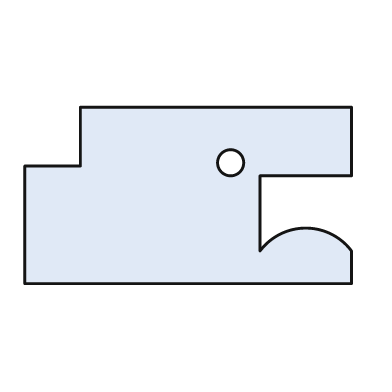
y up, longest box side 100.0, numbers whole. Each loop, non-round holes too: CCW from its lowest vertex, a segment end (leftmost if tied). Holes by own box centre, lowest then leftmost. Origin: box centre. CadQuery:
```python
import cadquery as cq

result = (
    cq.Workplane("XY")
    .moveTo(-50.0, -27.0)
    .lineTo(50.0, -27.0)
    .lineTo(50.0, -17.0)
    .threePointArc((36.0, -10.0), (22.0, -17.0))
    .lineTo(22.0, 6.0)
    .lineTo(50.0, 6.0)
    .lineTo(50.0, 27.0)
    .lineTo(-33.0, 27.0)
    .lineTo(-33.0, 9.0)
    .lineTo(-50.0, 9.0)
    .close()
    .moveTo(13.0, 10.0)
    .circle(4.0)
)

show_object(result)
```